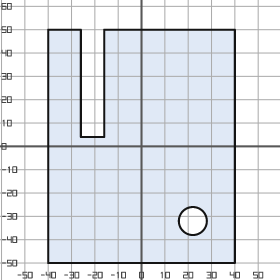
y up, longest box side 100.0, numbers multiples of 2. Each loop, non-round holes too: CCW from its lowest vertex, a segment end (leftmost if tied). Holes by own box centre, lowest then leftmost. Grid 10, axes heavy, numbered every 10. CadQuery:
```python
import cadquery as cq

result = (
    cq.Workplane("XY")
    .moveTo(-40.0, -50.0)
    .lineTo(40.0, -50.0)
    .lineTo(40.0, 50.0)
    .lineTo(-16.0, 50.0)
    .lineTo(-16.0, 4.0)
    .lineTo(-26.0, 4.0)
    .lineTo(-26.0, 50.0)
    .lineTo(-40.0, 50.0)
    .close()
    .moveTo(22.0, -32.0)
    .circle(6.0)
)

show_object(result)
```